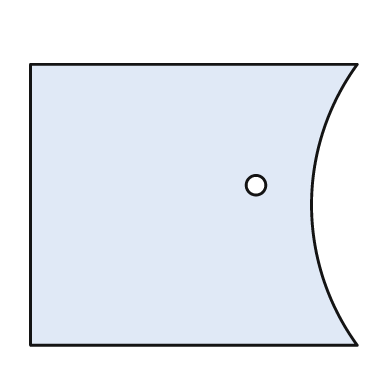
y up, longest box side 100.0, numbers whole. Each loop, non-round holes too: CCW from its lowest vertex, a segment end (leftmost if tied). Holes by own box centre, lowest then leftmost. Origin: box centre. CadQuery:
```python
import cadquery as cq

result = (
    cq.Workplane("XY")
    .moveTo(-50.0, -43.0)
    .lineTo(50.0, -43.0)
    .threePointArc((36.0, 0.0), (50.0, 43.0))
    .lineTo(-50.0, 43.0)
    .close()
    .moveTo(19.0, 6.0)
    .circle(3.0)
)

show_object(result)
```